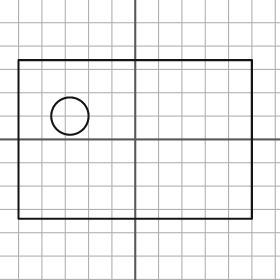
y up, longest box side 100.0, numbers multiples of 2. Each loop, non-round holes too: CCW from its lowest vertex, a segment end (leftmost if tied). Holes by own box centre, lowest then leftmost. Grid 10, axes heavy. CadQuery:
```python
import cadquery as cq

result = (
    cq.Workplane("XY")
    .moveTo(-50.0, -34.0)
    .lineTo(50.0, -34.0)
    .lineTo(50.0, 34.0)
    .lineTo(-50.0, 34.0)
    .close()
    .moveTo(-28.0, 10.0)
    .circle(8.0)
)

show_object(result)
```